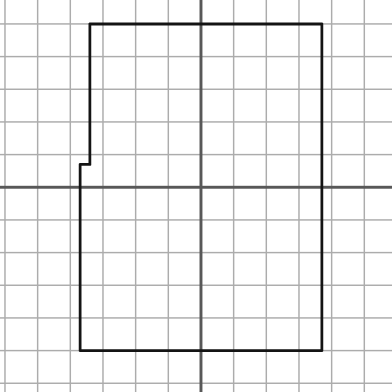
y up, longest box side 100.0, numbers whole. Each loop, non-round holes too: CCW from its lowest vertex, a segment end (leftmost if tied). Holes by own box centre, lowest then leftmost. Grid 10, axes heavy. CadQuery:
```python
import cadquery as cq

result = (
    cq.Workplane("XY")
    .moveTo(-37.0, -50.0)
    .lineTo(37.0, -50.0)
    .lineTo(37.0, 50.0)
    .lineTo(-34.0, 50.0)
    .lineTo(-34.0, 7.0)
    .lineTo(-37.0, 7.0)
    .close()
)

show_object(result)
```